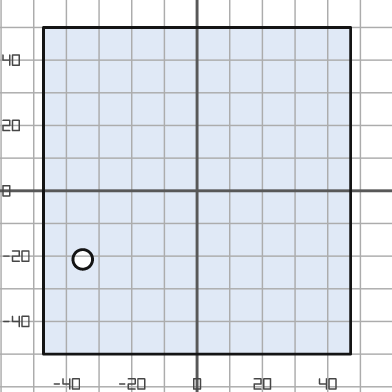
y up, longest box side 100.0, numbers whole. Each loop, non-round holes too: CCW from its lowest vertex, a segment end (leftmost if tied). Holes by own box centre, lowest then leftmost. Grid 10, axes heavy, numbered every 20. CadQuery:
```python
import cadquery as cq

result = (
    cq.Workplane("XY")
    .moveTo(-47.0, -50.0)
    .lineTo(47.0, -50.0)
    .lineTo(47.0, 50.0)
    .lineTo(-47.0, 50.0)
    .close()
    .moveTo(-35.0, -21.0)
    .circle(3.0)
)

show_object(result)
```